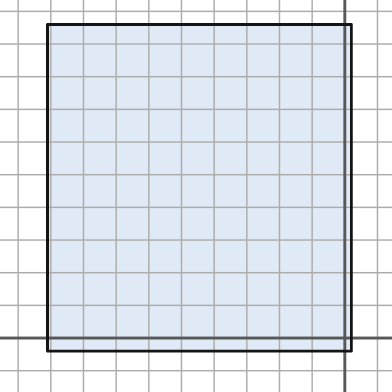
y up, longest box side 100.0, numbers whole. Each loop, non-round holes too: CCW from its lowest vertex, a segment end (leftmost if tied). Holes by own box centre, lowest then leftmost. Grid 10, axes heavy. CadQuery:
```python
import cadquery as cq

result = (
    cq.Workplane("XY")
    .moveTo(-91.0, -4.0)
    .lineTo(2.0, -4.0)
    .lineTo(2.0, 96.0)
    .lineTo(-91.0, 96.0)
    .close()
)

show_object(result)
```